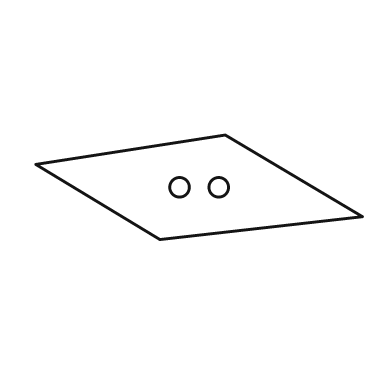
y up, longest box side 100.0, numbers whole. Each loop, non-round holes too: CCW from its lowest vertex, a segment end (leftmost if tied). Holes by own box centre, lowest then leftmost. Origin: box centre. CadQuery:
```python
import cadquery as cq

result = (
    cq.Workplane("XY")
    .moveTo(-12.0, -16.0)
    .lineTo(50.0, -9.0)
    .lineTo(8.0, 16.0)
    .lineTo(-50.0, 7.0)
    .close()
    .moveTo(-6.0, 0.0)
    .circle(3.0)
    .moveTo(6.0, 0.0)
    .circle(3.0)
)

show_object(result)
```